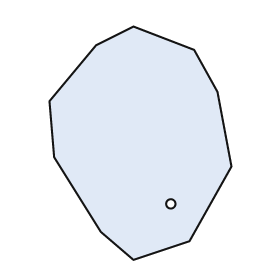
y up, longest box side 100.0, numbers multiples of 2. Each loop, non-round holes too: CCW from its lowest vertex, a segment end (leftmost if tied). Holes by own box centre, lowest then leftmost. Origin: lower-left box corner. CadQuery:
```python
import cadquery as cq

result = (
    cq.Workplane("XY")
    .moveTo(36.0, 0.0)
    .lineTo(60.0, 8.0)
    .lineTo(78.0, 40.0)
    .lineTo(72.0, 72.0)
    .lineTo(62.0, 90.0)
    .lineTo(36.0, 100.0)
    .lineTo(20.0, 92.0)
    .lineTo(0.0, 68.0)
    .lineTo(2.0, 44.0)
    .lineTo(22.0, 12.0)
    .close()
    .moveTo(52.0, 24.0)
    .circle(2.0)
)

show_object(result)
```